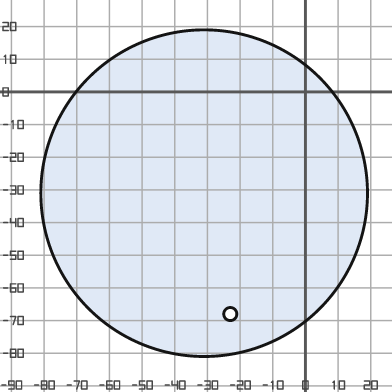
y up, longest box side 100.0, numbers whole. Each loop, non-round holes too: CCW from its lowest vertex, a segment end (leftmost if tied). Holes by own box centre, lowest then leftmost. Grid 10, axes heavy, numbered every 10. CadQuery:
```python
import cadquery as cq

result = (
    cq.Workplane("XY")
    .moveTo(-31.0, -31.0)
    .circle(50.0)
    .moveTo(-23.0, -68.0)
    .circle(2.0)
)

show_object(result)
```